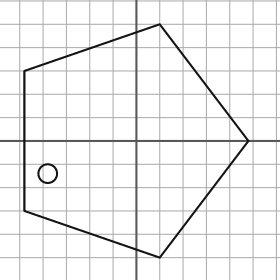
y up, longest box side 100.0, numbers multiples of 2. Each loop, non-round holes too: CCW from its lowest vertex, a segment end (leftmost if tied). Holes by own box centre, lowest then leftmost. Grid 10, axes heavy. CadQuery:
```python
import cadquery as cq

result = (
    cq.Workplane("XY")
    .moveTo(10.0, -50.0)
    .lineTo(48.0, 0.0)
    .lineTo(10.0, 50.0)
    .lineTo(-48.0, 30.0)
    .lineTo(-48.0, -30.0)
    .close()
    .moveTo(-38.0, -14.0)
    .circle(4.0)
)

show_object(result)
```